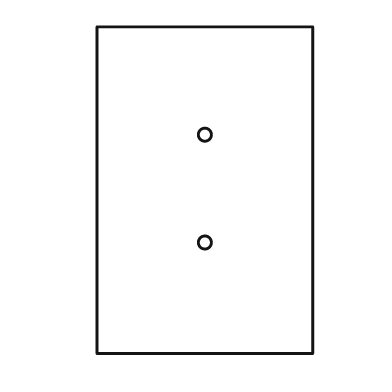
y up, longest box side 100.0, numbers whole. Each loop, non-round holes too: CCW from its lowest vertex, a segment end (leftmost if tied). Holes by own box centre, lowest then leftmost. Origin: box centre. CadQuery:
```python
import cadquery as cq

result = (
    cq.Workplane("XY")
    .moveTo(-33.0, -50.0)
    .lineTo(33.0, -50.0)
    .lineTo(33.0, 50.0)
    .lineTo(-33.0, 50.0)
    .close()
    .moveTo(0.0, -16.0)
    .circle(2.0)
    .moveTo(0.0, 17.0)
    .circle(2.0)
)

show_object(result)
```